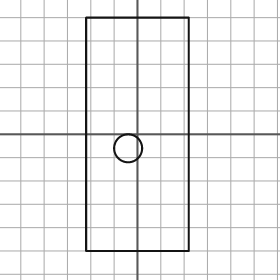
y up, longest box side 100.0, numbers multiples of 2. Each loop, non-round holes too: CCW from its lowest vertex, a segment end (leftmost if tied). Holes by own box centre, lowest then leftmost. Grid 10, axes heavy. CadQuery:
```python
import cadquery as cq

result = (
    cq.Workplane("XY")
    .moveTo(-22.0, -50.0)
    .lineTo(22.0, -50.0)
    .lineTo(22.0, 50.0)
    .lineTo(-22.0, 50.0)
    .close()
    .moveTo(-4.0, -6.0)
    .circle(6.0)
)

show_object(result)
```